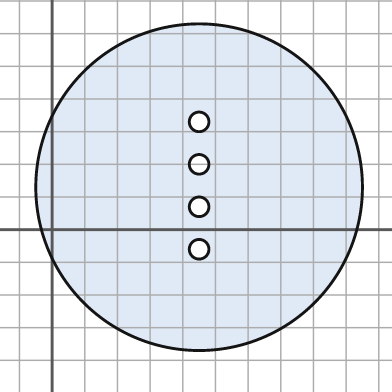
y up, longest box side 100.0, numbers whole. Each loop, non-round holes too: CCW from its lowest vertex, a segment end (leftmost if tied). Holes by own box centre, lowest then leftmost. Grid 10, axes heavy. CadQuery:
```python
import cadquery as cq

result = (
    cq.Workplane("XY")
    .moveTo(45.0, 13.0)
    .circle(50.0)
    .moveTo(45.0, -6.0)
    .circle(3.0)
    .moveTo(45.0, 7.0)
    .circle(3.0)
    .moveTo(45.0, 20.0)
    .circle(3.0)
    .moveTo(45.0, 33.0)
    .circle(3.0)
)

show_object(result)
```